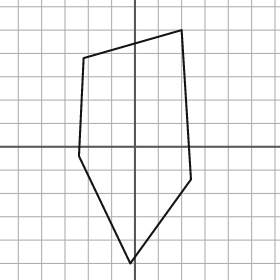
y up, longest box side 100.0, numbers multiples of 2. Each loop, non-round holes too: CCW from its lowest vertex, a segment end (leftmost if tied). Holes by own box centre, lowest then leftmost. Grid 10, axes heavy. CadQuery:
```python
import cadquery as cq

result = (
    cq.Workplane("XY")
    .moveTo(-2.0, -50.0)
    .lineTo(24.0, -14.0)
    .lineTo(20.0, 50.0)
    .lineTo(-22.0, 38.0)
    .lineTo(-24.0, -4.0)
    .close()
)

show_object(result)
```